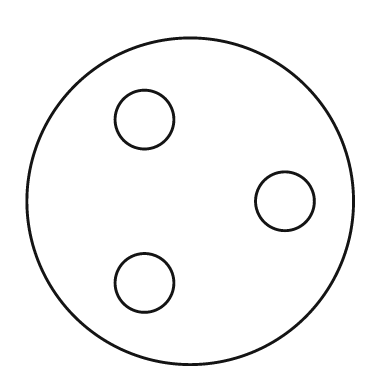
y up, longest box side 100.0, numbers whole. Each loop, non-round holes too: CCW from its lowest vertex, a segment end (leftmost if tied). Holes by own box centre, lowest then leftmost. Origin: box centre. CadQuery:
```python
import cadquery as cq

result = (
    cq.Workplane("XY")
    .moveTo(0.0, 0.0)
    .circle(50.0)
    .moveTo(-14.0, -25.0)
    .circle(9.0)
    .moveTo(29.0, 0.0)
    .circle(9.0)
    .moveTo(-14.0, 25.0)
    .circle(9.0)
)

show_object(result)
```